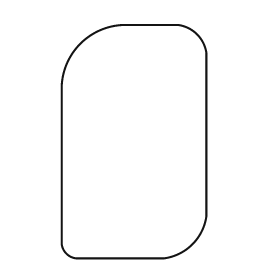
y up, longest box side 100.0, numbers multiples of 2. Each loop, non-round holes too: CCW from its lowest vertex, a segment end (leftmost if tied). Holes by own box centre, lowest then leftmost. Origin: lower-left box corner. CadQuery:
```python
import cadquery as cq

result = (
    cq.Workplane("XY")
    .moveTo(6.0, 0.0)
    .lineTo(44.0, 0.0)
    .threePointArc((56.0, 6.0), (62.0, 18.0))
    .lineTo(62.0, 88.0)
    .threePointArc((58.0, 96.0), (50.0, 100.0))
    .lineTo(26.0, 100.0)
    .threePointArc((8.0, 92.0), (0.0, 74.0))
    .lineTo(0.0, 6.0)
    .threePointArc((2.0, 2.0), (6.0, 0.0))
    .close()
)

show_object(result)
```